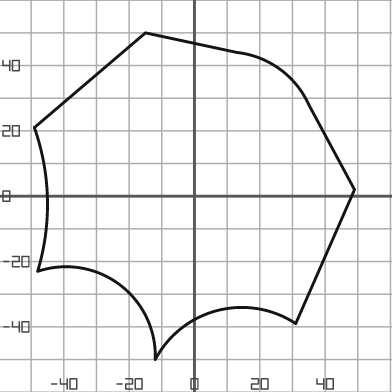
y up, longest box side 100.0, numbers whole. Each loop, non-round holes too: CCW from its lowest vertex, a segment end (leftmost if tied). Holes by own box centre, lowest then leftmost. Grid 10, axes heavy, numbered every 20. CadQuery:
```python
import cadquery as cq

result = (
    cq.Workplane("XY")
    .moveTo(-12.0, -50.0)
    .threePointArc((7.0, -35.0), (31.0, -39.0))
    .lineTo(49.0, 2.0)
    .lineTo(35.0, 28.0)
    .threePointArc((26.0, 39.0), (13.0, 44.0))
    .lineTo(-15.0, 50.0)
    .lineTo(-49.0, 21.0)
    .threePointArc((-45.0, -1.0), (-48.0, -23.0))
    .threePointArc((-23.0, -27.0), (-12.0, -50.0))
    .close()
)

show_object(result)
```